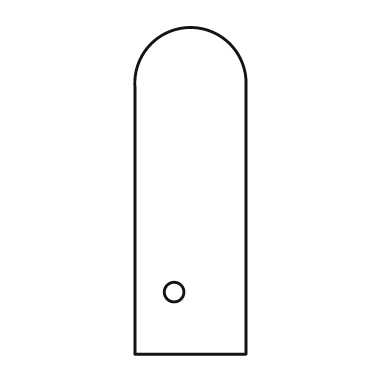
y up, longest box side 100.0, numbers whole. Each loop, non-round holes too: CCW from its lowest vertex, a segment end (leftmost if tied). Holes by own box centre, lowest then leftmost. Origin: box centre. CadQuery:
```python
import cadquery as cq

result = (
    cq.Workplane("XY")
    .moveTo(-17.0, -50.0)
    .lineTo(17.0, -50.0)
    .lineTo(17.0, 32.0)
    .threePointArc((0.0, 50.0), (-17.0, 32.0))
    .close()
    .moveTo(-5.0, -31.0)
    .circle(3.0)
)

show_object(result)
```